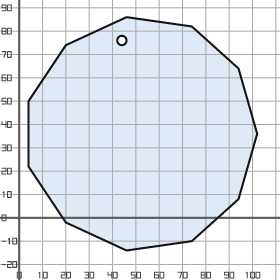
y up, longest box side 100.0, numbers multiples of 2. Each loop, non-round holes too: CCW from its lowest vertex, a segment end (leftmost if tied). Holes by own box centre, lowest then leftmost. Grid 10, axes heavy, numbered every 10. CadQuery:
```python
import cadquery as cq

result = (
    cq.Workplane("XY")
    .moveTo(46.0, -14.0)
    .lineTo(74.0, -10.0)
    .lineTo(94.0, 8.0)
    .lineTo(102.0, 36.0)
    .lineTo(94.0, 64.0)
    .lineTo(74.0, 82.0)
    .lineTo(46.0, 86.0)
    .lineTo(20.0, 74.0)
    .lineTo(4.0, 50.0)
    .lineTo(4.0, 22.0)
    .lineTo(20.0, -2.0)
    .close()
    .moveTo(44.0, 76.0)
    .circle(2.0)
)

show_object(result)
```